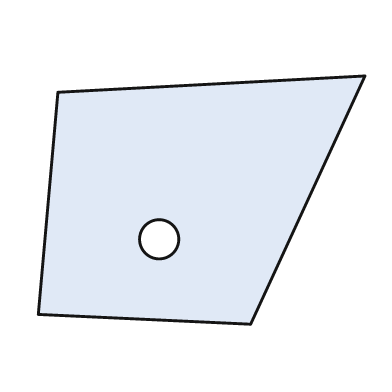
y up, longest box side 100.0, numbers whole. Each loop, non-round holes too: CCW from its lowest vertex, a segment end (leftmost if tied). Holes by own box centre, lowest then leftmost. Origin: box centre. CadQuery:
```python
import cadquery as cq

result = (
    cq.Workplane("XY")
    .moveTo(15.0, -38.0)
    .lineTo(50.0, 38.0)
    .lineTo(-44.0, 33.0)
    .lineTo(-50.0, -35.0)
    .close()
    .moveTo(-13.0, -12.0)
    .circle(6.0)
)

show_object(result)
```